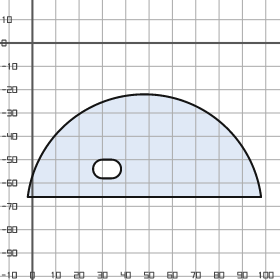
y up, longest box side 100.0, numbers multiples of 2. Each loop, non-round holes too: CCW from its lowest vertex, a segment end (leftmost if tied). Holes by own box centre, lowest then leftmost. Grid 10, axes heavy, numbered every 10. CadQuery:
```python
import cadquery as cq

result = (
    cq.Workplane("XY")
    .moveTo(-2.0, -66.0)
    .lineTo(98.0, -66.0)
    .threePointArc((48.0, -22.0), (-2.0, -66.0))
    .close()
    .moveTo(30.0, -58.0)
    .lineTo(34.0, -58.0)
    .threePointArc((38.0, -54.0), (34.0, -50.0))
    .lineTo(30.0, -50.0)
    .threePointArc((26.0, -54.0), (30.0, -58.0))
    .close()
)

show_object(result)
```